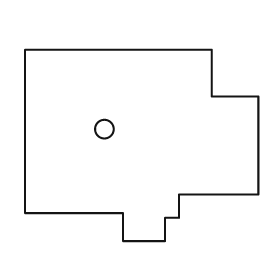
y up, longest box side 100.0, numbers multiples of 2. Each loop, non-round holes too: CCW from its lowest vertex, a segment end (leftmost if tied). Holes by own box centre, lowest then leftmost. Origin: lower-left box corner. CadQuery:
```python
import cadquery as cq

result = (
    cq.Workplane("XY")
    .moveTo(42.0, 0.0)
    .lineTo(60.0, 0.0)
    .lineTo(60.0, 10.0)
    .lineTo(66.0, 10.0)
    .lineTo(66.0, 20.0)
    .lineTo(100.0, 20.0)
    .lineTo(100.0, 62.0)
    .lineTo(80.0, 62.0)
    .lineTo(80.0, 82.0)
    .lineTo(0.0, 82.0)
    .lineTo(0.0, 12.0)
    .lineTo(42.0, 12.0)
    .close()
    .moveTo(34.0, 48.0)
    .circle(4.0)
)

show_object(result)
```